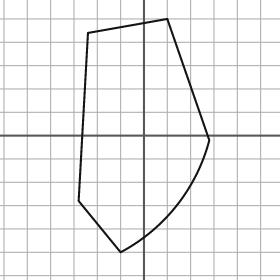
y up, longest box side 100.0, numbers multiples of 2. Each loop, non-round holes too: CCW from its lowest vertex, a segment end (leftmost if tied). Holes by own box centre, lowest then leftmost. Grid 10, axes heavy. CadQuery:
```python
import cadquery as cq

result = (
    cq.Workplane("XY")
    .moveTo(-10.0, -50.0)
    .threePointArc((14.0, -30.0), (28.0, -2.0))
    .lineTo(10.0, 50.0)
    .lineTo(-24.0, 44.0)
    .lineTo(-28.0, -28.0)
    .close()
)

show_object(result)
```